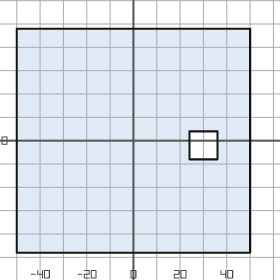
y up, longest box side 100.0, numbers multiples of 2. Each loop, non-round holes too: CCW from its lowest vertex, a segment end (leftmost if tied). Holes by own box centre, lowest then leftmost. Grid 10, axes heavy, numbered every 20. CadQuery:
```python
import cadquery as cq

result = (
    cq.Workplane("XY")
    .moveTo(-50.0, -48.0)
    .lineTo(50.0, -48.0)
    .lineTo(50.0, 48.0)
    .lineTo(-50.0, 48.0)
    .close()
    .moveTo(24.0, -8.0)
    .lineTo(36.0, -8.0)
    .lineTo(36.0, 4.0)
    .lineTo(24.0, 4.0)
    .close()
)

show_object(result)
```